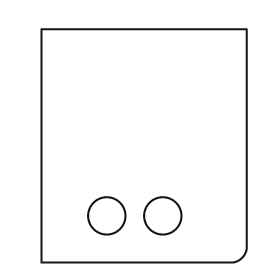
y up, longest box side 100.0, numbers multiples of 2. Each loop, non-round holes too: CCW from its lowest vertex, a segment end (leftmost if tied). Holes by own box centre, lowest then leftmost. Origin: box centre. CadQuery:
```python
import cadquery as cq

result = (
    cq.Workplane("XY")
    .moveTo(-44.0, -50.0)
    .lineTo(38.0, -50.0)
    .threePointArc((42.0, -48.0), (44.0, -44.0))
    .lineTo(44.0, 50.0)
    .lineTo(-44.0, 50.0)
    .close()
    .moveTo(-16.0, -30.0)
    .circle(8.0)
    .moveTo(8.0, -30.0)
    .circle(8.0)
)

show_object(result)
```